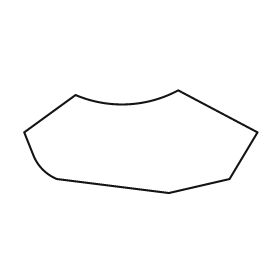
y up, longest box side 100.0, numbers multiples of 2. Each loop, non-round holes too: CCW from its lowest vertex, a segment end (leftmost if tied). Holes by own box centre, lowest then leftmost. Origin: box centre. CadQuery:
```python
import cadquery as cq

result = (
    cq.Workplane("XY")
    .moveTo(12.0, -22.0)
    .lineTo(38.0, -16.0)
    .lineTo(50.0, 4.0)
    .lineTo(16.0, 22.0)
    .threePointArc((-6.0, 16.0), (-28.0, 20.0))
    .lineTo(-50.0, 4.0)
    .lineTo(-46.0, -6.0)
    .threePointArc((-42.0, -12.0), (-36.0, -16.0))
    .close()
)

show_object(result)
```